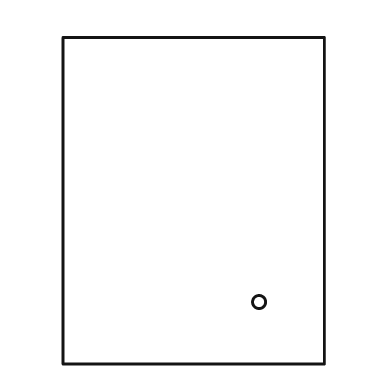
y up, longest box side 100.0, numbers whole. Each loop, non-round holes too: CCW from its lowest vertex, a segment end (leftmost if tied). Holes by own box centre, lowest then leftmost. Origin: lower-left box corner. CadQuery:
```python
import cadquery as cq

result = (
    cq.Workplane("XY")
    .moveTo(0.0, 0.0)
    .lineTo(80.0, 0.0)
    .lineTo(80.0, 100.0)
    .lineTo(0.0, 100.0)
    .close()
    .moveTo(60.0, 19.0)
    .circle(2.0)
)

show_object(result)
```